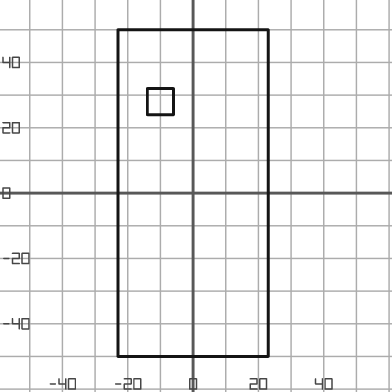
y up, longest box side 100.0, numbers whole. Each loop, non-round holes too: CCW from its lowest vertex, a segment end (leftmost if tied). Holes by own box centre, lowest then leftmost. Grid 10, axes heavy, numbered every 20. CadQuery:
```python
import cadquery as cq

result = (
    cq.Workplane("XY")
    .moveTo(-23.0, -50.0)
    .lineTo(23.0, -50.0)
    .lineTo(23.0, 50.0)
    .lineTo(-23.0, 50.0)
    .close()
    .moveTo(-14.0, 24.0)
    .lineTo(-6.0, 24.0)
    .lineTo(-6.0, 32.0)
    .lineTo(-14.0, 32.0)
    .close()
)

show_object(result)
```